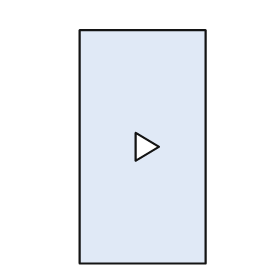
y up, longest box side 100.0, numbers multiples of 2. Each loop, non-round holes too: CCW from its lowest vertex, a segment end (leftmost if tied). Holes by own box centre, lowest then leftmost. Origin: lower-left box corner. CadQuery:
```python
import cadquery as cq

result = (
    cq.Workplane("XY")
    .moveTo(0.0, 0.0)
    .lineTo(54.0, 0.0)
    .lineTo(54.0, 100.0)
    .lineTo(0.0, 100.0)
    .close()
    .moveTo(24.0, 44.0)
    .lineTo(34.0, 50.0)
    .lineTo(24.0, 56.0)
    .close()
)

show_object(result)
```